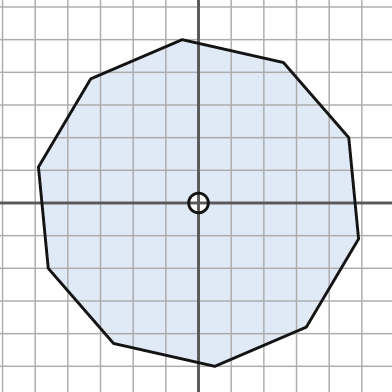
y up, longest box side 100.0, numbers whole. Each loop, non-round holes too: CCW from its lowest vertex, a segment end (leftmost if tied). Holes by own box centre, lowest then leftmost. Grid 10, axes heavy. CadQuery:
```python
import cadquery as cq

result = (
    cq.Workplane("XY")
    .moveTo(5.0, -50.0)
    .lineTo(33.0, -38.0)
    .lineTo(49.0, -11.0)
    .lineTo(46.0, 20.0)
    .lineTo(26.0, 43.0)
    .lineTo(-5.0, 50.0)
    .lineTo(-33.0, 38.0)
    .lineTo(-49.0, 11.0)
    .lineTo(-46.0, -20.0)
    .lineTo(-26.0, -43.0)
    .close()
    .moveTo(0.0, 0.0)
    .circle(3.0)
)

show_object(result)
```